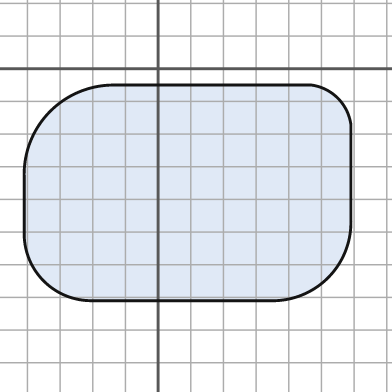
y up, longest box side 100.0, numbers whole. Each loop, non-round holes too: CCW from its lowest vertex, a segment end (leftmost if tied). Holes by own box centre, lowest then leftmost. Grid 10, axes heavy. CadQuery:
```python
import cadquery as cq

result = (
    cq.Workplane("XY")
    .moveTo(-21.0, -71.0)
    .lineTo(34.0, -71.0)
    .threePointArc((52.0, -64.0), (59.0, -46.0))
    .lineTo(59.0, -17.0)
    .threePointArc((55.0, -9.0), (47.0, -5.0))
    .lineTo(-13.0, -5.0)
    .threePointArc((-33.0, -13.0), (-41.0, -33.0))
    .lineTo(-41.0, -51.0)
    .threePointArc((-35.0, -65.0), (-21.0, -71.0))
    .close()
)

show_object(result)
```